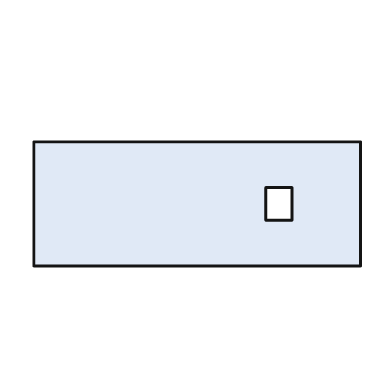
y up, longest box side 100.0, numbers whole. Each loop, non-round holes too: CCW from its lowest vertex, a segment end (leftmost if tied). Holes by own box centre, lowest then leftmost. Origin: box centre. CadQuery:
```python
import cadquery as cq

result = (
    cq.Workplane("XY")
    .moveTo(-50.0, -19.0)
    .lineTo(50.0, -19.0)
    .lineTo(50.0, 19.0)
    .lineTo(-50.0, 19.0)
    .close()
    .moveTo(21.0, -5.0)
    .lineTo(29.0, -5.0)
    .lineTo(29.0, 5.0)
    .lineTo(21.0, 5.0)
    .close()
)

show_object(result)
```